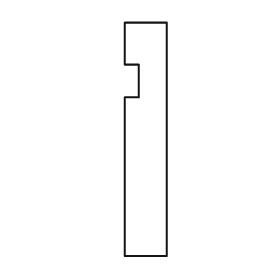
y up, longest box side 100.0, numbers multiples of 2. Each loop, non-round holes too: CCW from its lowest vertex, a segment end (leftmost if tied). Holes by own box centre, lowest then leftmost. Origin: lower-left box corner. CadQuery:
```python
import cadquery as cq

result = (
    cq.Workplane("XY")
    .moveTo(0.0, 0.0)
    .lineTo(18.0, 0.0)
    .lineTo(18.0, 100.0)
    .lineTo(0.0, 100.0)
    .lineTo(0.0, 82.0)
    .lineTo(6.0, 82.0)
    .lineTo(6.0, 68.0)
    .lineTo(0.0, 68.0)
    .close()
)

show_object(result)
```